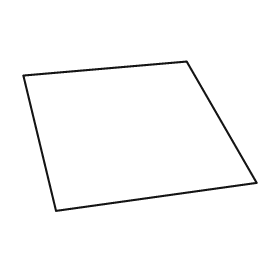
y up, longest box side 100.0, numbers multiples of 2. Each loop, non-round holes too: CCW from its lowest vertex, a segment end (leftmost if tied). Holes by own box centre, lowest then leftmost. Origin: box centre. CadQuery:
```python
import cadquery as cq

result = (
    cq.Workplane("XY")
    .moveTo(-36.0, -32.0)
    .lineTo(50.0, -20.0)
    .lineTo(20.0, 32.0)
    .lineTo(-50.0, 26.0)
    .close()
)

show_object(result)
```